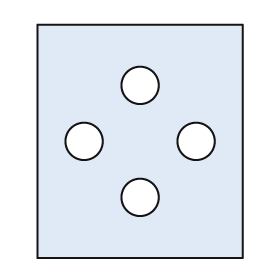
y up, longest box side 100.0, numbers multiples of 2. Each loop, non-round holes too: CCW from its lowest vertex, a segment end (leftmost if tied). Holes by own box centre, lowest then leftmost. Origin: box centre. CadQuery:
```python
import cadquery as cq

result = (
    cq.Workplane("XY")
    .moveTo(-44.0, -50.0)
    .lineTo(44.0, -50.0)
    .lineTo(44.0, 50.0)
    .lineTo(-44.0, 50.0)
    .close()
    .moveTo(0.0, -24.0)
    .circle(8.0)
    .moveTo(-24.0, 0.0)
    .circle(8.0)
    .moveTo(24.0, 0.0)
    .circle(8.0)
    .moveTo(0.0, 24.0)
    .circle(8.0)
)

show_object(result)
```